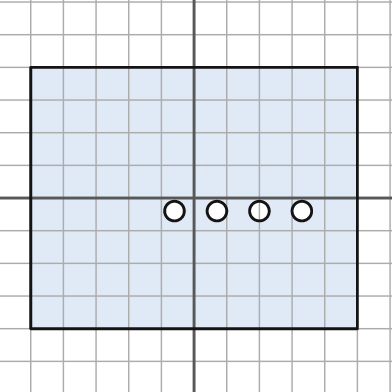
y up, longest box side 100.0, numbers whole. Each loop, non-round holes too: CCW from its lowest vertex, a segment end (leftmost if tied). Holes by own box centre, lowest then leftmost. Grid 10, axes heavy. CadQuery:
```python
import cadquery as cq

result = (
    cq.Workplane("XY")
    .moveTo(-50.0, -40.0)
    .lineTo(50.0, -40.0)
    .lineTo(50.0, 40.0)
    .lineTo(-50.0, 40.0)
    .close()
    .moveTo(-6.0, -4.0)
    .circle(3.0)
    .moveTo(7.0, -4.0)
    .circle(3.0)
    .moveTo(20.0, -4.0)
    .circle(3.0)
    .moveTo(33.0, -4.0)
    .circle(3.0)
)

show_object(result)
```